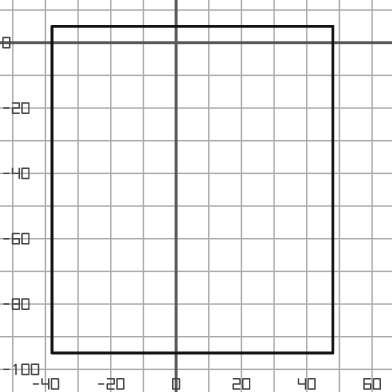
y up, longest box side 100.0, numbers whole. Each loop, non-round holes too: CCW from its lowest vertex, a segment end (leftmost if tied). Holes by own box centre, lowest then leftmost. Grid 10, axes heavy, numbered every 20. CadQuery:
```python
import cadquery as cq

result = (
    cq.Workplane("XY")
    .moveTo(-38.0, -95.0)
    .lineTo(48.0, -95.0)
    .lineTo(48.0, 5.0)
    .lineTo(-38.0, 5.0)
    .close()
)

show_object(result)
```